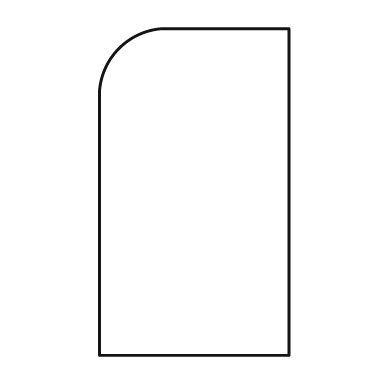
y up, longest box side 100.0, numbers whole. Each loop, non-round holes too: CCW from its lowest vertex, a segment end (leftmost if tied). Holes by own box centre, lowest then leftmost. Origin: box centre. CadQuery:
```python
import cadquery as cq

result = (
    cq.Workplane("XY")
    .moveTo(-29.0, -50.0)
    .lineTo(29.0, -50.0)
    .lineTo(29.0, 50.0)
    .lineTo(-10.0, 50.0)
    .threePointArc((-23.0, 44.0), (-29.0, 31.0))
    .close()
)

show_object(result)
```